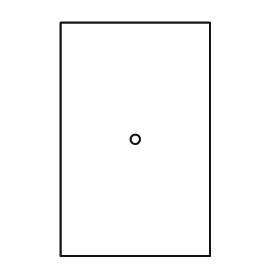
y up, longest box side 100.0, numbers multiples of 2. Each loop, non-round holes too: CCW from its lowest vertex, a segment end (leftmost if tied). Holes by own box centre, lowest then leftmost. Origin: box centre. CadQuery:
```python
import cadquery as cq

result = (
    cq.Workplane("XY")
    .moveTo(-32.0, -50.0)
    .lineTo(32.0, -50.0)
    .lineTo(32.0, 50.0)
    .lineTo(-32.0, 50.0)
    .close()
    .moveTo(0.0, 0.0)
    .circle(2.0)
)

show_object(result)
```